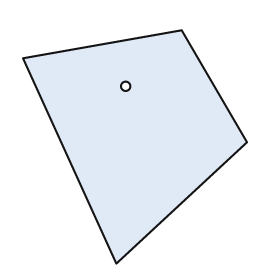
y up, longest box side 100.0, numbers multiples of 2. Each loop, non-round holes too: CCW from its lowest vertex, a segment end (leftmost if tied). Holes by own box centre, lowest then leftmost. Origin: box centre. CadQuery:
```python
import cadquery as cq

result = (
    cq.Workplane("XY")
    .moveTo(-8.0, -50.0)
    .lineTo(48.0, 2.0)
    .lineTo(20.0, 50.0)
    .lineTo(-48.0, 38.0)
    .close()
    .moveTo(-4.0, 26.0)
    .circle(2.0)
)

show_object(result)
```